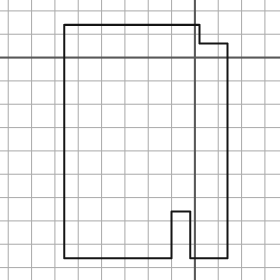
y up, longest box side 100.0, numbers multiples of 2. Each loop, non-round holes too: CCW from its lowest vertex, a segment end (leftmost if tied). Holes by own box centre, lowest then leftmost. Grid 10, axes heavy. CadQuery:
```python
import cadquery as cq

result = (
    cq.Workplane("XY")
    .moveTo(-56.0, -86.0)
    .lineTo(-10.0, -86.0)
    .lineTo(-10.0, -66.0)
    .lineTo(-2.0, -66.0)
    .lineTo(-2.0, -86.0)
    .lineTo(14.0, -86.0)
    .lineTo(14.0, 6.0)
    .lineTo(2.0, 6.0)
    .lineTo(2.0, 14.0)
    .lineTo(-56.0, 14.0)
    .close()
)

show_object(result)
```